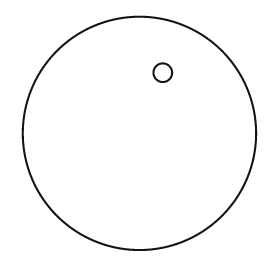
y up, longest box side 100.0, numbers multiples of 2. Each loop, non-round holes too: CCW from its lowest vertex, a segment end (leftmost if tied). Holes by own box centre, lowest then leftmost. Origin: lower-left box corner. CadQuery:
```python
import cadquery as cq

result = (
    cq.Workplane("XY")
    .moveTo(50.0, 50.0)
    .circle(50.0)
    .moveTo(60.0, 76.0)
    .circle(4.0)
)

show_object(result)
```